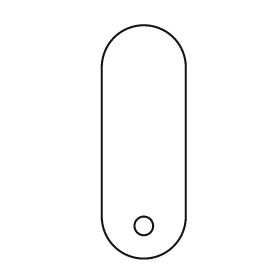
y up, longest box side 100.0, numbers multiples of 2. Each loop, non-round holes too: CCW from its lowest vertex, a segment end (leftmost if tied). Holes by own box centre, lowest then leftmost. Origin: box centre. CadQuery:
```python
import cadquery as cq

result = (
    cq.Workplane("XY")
    .moveTo(-18.0, -32.0)
    .threePointArc((0.0, -50.0), (18.0, -32.0))
    .lineTo(18.0, 32.0)
    .threePointArc((0.0, 50.0), (-18.0, 32.0))
    .close()
    .moveTo(0.0, -36.0)
    .circle(4.0)
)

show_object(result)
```